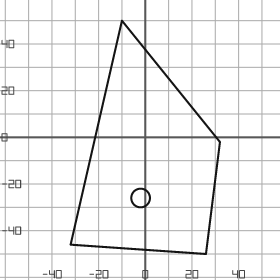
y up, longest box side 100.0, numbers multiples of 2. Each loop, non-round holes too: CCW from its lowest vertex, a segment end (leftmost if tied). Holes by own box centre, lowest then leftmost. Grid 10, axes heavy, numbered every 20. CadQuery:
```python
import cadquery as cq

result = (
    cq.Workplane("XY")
    .moveTo(26.0, -50.0)
    .lineTo(32.0, -2.0)
    .lineTo(-10.0, 50.0)
    .lineTo(-32.0, -46.0)
    .close()
    .moveTo(-2.0, -26.0)
    .circle(4.0)
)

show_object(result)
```